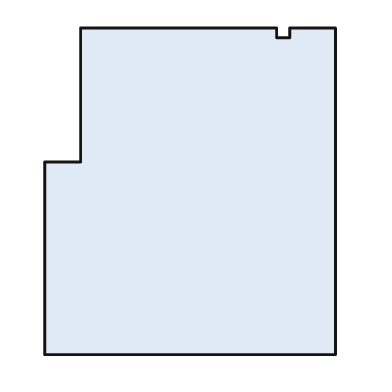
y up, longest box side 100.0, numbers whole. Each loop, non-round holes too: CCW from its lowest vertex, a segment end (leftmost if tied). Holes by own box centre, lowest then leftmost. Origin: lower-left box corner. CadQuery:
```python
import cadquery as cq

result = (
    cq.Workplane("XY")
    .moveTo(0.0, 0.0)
    .lineTo(89.0, 0.0)
    .lineTo(89.0, 100.0)
    .lineTo(75.0, 100.0)
    .lineTo(75.0, 97.0)
    .lineTo(71.0, 97.0)
    .lineTo(71.0, 100.0)
    .lineTo(11.0, 100.0)
    .lineTo(11.0, 59.0)
    .lineTo(0.0, 59.0)
    .close()
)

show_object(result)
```